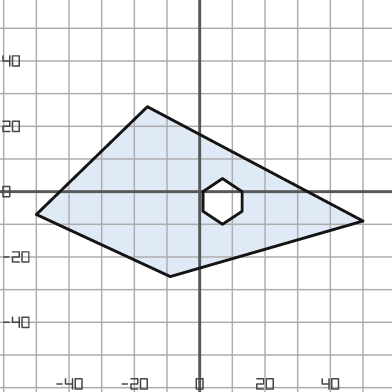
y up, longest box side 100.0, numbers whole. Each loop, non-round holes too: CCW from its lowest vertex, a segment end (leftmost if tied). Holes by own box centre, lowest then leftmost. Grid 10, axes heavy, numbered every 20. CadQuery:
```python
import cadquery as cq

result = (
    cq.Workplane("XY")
    .moveTo(-9.0, -26.0)
    .lineTo(50.0, -9.0)
    .lineTo(-16.0, 26.0)
    .lineTo(-50.0, -7.0)
    .close()
    .moveTo(7.0, -10.0)
    .lineTo(13.0, -6.0)
    .lineTo(13.0, 0.0)
    .lineTo(7.0, 4.0)
    .lineTo(1.0, 0.0)
    .lineTo(1.0, -6.0)
    .close()
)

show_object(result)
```